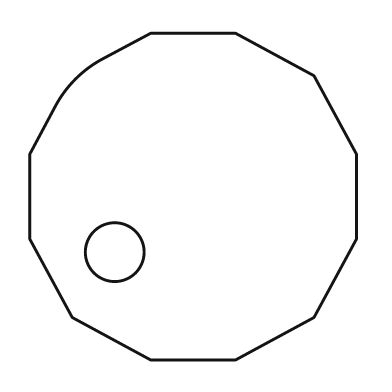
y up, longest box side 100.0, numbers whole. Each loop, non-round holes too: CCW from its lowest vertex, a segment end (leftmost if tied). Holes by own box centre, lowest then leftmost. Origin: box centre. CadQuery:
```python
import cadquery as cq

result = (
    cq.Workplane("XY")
    .moveTo(-13.0, -50.0)
    .lineTo(13.0, -50.0)
    .lineTo(37.0, -37.0)
    .lineTo(50.0, -13.0)
    .lineTo(50.0, 13.0)
    .lineTo(37.0, 37.0)
    .lineTo(13.0, 50.0)
    .lineTo(-13.0, 50.0)
    .lineTo(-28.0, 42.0)
    .threePointArc((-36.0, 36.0), (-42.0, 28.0))
    .lineTo(-50.0, 13.0)
    .lineTo(-50.0, -13.0)
    .lineTo(-37.0, -37.0)
    .close()
    .moveTo(-24.0, -17.0)
    .circle(9.0)
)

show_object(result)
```